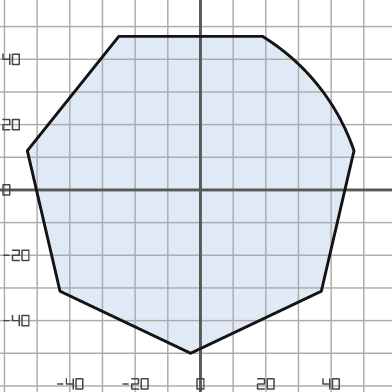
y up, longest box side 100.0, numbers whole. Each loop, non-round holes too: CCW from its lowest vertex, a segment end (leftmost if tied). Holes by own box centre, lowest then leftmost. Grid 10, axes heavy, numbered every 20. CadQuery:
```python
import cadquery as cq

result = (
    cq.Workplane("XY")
    .moveTo(-3.0, -50.0)
    .lineTo(37.0, -31.0)
    .lineTo(47.0, 12.0)
    .threePointArc((36.0, 32.0), (19.0, 47.0))
    .lineTo(-25.0, 47.0)
    .lineTo(-53.0, 12.0)
    .lineTo(-43.0, -31.0)
    .close()
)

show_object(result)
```